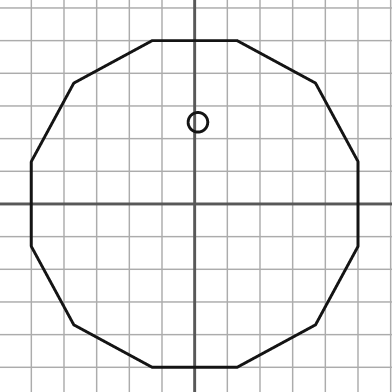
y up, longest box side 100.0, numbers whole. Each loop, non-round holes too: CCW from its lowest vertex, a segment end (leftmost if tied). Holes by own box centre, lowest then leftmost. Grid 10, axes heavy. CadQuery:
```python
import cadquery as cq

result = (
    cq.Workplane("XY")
    .moveTo(-13.0, -50.0)
    .lineTo(13.0, -50.0)
    .lineTo(37.0, -37.0)
    .lineTo(50.0, -13.0)
    .lineTo(50.0, 13.0)
    .lineTo(37.0, 37.0)
    .lineTo(13.0, 50.0)
    .lineTo(-13.0, 50.0)
    .lineTo(-37.0, 37.0)
    .lineTo(-50.0, 13.0)
    .lineTo(-50.0, -13.0)
    .lineTo(-37.0, -37.0)
    .close()
    .moveTo(1.0, 25.0)
    .circle(3.0)
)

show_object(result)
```